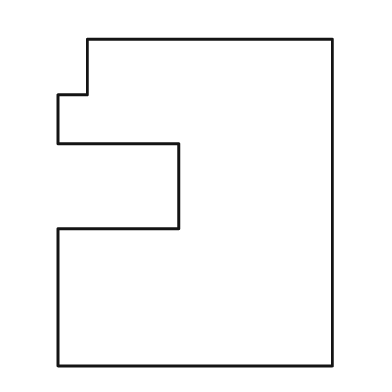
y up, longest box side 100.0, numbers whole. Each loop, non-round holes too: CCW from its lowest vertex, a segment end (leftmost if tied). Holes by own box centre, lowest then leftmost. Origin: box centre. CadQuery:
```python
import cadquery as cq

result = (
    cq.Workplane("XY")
    .moveTo(-42.0, -50.0)
    .lineTo(42.0, -50.0)
    .lineTo(42.0, 50.0)
    .lineTo(-33.0, 50.0)
    .lineTo(-33.0, 33.0)
    .lineTo(-42.0, 33.0)
    .lineTo(-42.0, 18.0)
    .lineTo(-5.0, 18.0)
    .lineTo(-5.0, -8.0)
    .lineTo(-42.0, -8.0)
    .close()
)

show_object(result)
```